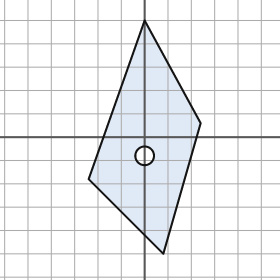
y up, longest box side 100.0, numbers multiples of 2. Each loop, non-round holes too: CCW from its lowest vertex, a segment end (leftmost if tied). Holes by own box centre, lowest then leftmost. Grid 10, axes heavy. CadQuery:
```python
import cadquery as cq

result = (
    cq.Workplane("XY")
    .moveTo(8.0, -50.0)
    .lineTo(24.0, 6.0)
    .lineTo(0.0, 50.0)
    .lineTo(-24.0, -18.0)
    .close()
    .moveTo(0.0, -8.0)
    .circle(4.0)
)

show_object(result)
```